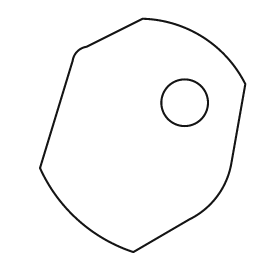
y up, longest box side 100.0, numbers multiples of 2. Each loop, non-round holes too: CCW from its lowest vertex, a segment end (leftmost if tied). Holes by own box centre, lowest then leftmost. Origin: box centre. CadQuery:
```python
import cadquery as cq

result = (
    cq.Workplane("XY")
    .moveTo(-4.0, -50.0)
    .lineTo(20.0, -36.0)
    .threePointArc((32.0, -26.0), (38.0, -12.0))
    .lineTo(44.0, 22.0)
    .threePointArc((26.0, 42.0), (0.0, 50.0))
    .lineTo(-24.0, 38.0)
    .threePointArc((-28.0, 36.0), (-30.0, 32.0))
    .lineTo(-44.0, -14.0)
    .threePointArc((-28.0, -36.0), (-4.0, -50.0))
    .close()
    .moveTo(18.0, 14.0)
    .circle(10.0)
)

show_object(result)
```